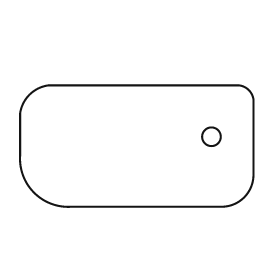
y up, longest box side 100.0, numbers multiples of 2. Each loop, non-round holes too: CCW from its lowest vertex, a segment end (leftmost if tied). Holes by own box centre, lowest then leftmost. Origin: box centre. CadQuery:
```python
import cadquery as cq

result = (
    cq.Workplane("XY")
    .moveTo(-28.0, -26.0)
    .lineTo(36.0, -26.0)
    .threePointArc((46.0, -22.0), (50.0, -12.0))
    .lineTo(50.0, 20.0)
    .threePointArc((48.0, 24.0), (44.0, 26.0))
    .lineTo(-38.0, 26.0)
    .threePointArc((-46.0, 22.0), (-50.0, 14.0))
    .lineTo(-50.0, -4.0)
    .threePointArc((-44.0, -20.0), (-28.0, -26.0))
    .close()
    .moveTo(32.0, 4.0)
    .circle(4.0)
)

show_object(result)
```